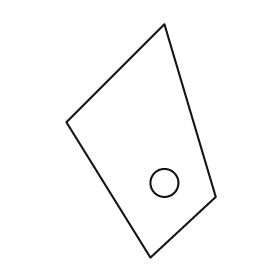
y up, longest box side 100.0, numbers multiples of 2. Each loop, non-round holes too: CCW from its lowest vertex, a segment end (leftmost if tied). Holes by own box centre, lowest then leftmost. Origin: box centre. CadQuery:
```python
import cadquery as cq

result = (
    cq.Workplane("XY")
    .moveTo(4.0, -50.0)
    .lineTo(32.0, -24.0)
    .lineTo(10.0, 50.0)
    .lineTo(-32.0, 8.0)
    .close()
    .moveTo(10.0, -18.0)
    .circle(6.0)
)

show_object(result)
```